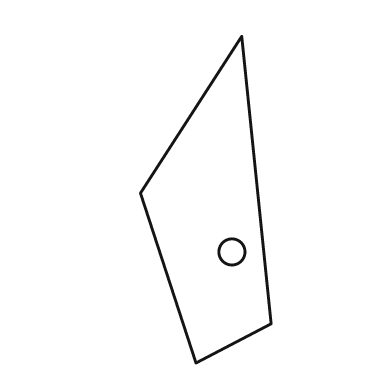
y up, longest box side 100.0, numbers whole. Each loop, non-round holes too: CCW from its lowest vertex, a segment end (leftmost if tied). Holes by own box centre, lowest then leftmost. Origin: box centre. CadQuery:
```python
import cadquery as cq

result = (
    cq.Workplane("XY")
    .moveTo(-3.0, -50.0)
    .lineTo(20.0, -38.0)
    .lineTo(11.0, 50.0)
    .lineTo(-20.0, 2.0)
    .close()
    .moveTo(8.0, -16.0)
    .circle(4.0)
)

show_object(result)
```